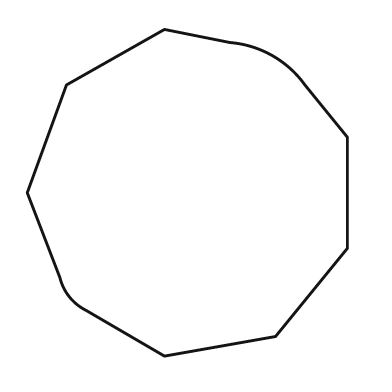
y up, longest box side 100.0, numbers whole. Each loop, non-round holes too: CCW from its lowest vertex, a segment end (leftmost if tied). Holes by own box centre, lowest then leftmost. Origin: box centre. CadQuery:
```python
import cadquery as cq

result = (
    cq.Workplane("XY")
    .moveTo(-7.0, -50.0)
    .lineTo(27.0, -44.0)
    .lineTo(49.0, -17.0)
    .lineTo(49.0, 17.0)
    .lineTo(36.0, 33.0)
    .threePointArc((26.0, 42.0), (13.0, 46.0))
    .lineTo(-7.0, 50.0)
    .lineTo(-37.0, 33.0)
    .lineTo(-49.0, 0.0)
    .lineTo(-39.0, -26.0)
    .threePointArc((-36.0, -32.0), (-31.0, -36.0))
    .close()
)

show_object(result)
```